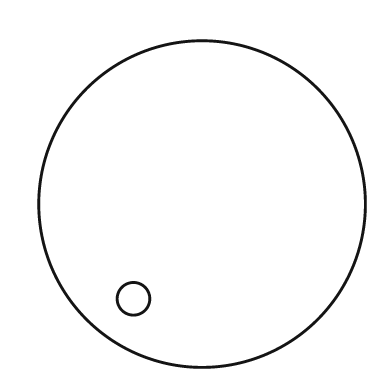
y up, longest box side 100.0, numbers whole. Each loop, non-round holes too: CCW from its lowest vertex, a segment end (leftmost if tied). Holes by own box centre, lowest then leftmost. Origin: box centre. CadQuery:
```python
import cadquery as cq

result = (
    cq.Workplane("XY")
    .moveTo(0.0, 0.0)
    .circle(50.0)
    .moveTo(-21.0, -29.0)
    .circle(5.0)
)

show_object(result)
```